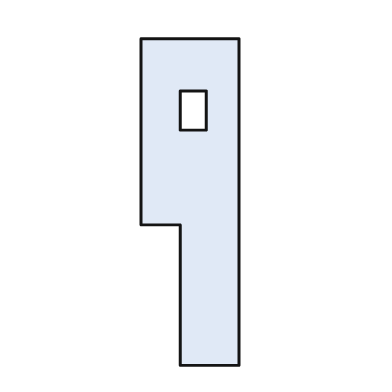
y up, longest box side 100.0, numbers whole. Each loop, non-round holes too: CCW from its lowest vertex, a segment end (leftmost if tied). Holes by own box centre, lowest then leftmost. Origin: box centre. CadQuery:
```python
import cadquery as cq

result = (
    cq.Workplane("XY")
    .moveTo(-3.0, -50.0)
    .lineTo(15.0, -50.0)
    .lineTo(15.0, 50.0)
    .lineTo(-15.0, 50.0)
    .lineTo(-15.0, -7.0)
    .lineTo(-3.0, -7.0)
    .close()
    .moveTo(-3.0, 22.0)
    .lineTo(5.0, 22.0)
    .lineTo(5.0, 34.0)
    .lineTo(-3.0, 34.0)
    .close()
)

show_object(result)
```